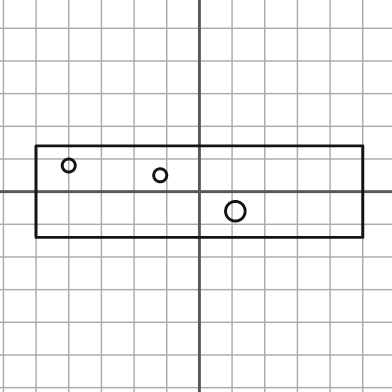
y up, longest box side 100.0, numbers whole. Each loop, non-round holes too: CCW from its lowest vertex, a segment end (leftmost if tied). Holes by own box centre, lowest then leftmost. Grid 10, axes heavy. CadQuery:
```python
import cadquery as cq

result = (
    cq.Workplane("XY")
    .moveTo(-50.0, -14.0)
    .lineTo(50.0, -14.0)
    .lineTo(50.0, 14.0)
    .lineTo(-50.0, 14.0)
    .close()
    .moveTo(11.0, -6.0)
    .circle(3.0)
    .moveTo(-12.0, 5.0)
    .circle(2.0)
    .moveTo(-40.0, 8.0)
    .circle(2.0)
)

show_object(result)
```